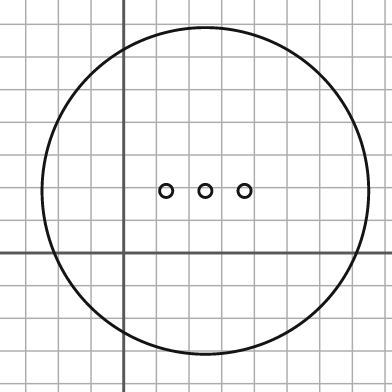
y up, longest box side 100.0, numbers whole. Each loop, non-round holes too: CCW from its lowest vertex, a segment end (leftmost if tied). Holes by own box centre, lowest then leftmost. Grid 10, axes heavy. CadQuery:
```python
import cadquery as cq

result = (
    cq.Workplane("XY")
    .moveTo(25.0, 19.0)
    .circle(50.0)
    .moveTo(13.0, 19.0)
    .circle(2.0)
    .moveTo(25.0, 19.0)
    .circle(2.0)
    .moveTo(37.0, 19.0)
    .circle(2.0)
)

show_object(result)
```